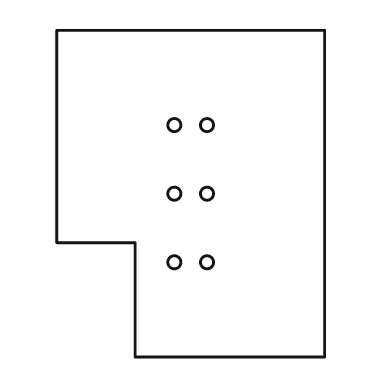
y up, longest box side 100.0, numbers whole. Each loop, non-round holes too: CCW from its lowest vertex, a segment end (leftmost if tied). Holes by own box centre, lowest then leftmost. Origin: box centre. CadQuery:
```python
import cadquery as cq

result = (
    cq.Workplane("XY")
    .moveTo(-17.0, -50.0)
    .lineTo(41.0, -50.0)
    .lineTo(41.0, 50.0)
    .lineTo(-41.0, 50.0)
    .lineTo(-41.0, -15.0)
    .lineTo(-17.0, -15.0)
    .close()
    .moveTo(-5.0, -21.0)
    .circle(2.0)
    .moveTo(5.0, -21.0)
    .circle(2.0)
    .moveTo(-5.0, 0.0)
    .circle(2.0)
    .moveTo(5.0, 0.0)
    .circle(2.0)
    .moveTo(-5.0, 21.0)
    .circle(2.0)
    .moveTo(5.0, 21.0)
    .circle(2.0)
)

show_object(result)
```